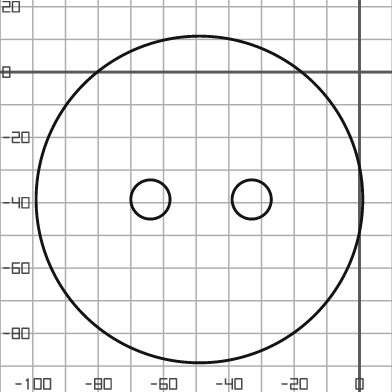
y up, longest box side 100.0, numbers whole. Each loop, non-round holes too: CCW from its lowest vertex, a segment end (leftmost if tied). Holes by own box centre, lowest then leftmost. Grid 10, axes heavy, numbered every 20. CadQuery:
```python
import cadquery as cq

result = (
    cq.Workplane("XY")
    .moveTo(-49.0, -39.0)
    .circle(50.0)
    .moveTo(-64.0, -39.0)
    .circle(6.0)
    .moveTo(-33.0, -39.0)
    .circle(6.0)
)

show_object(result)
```